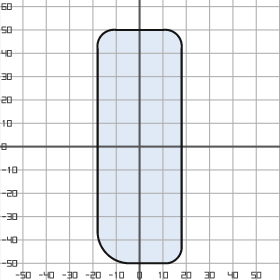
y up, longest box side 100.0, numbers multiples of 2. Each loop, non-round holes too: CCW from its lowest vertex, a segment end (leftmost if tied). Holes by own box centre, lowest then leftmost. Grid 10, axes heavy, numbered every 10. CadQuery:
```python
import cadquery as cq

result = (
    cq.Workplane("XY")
    .moveTo(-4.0, -50.0)
    .lineTo(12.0, -50.0)
    .threePointArc((16.0, -48.0), (18.0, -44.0))
    .lineTo(18.0, 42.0)
    .threePointArc((16.0, 48.0), (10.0, 50.0))
    .lineTo(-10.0, 50.0)
    .threePointArc((-16.0, 48.0), (-18.0, 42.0))
    .lineTo(-18.0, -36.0)
    .threePointArc((-14.0, -46.0), (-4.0, -50.0))
    .close()
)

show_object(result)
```